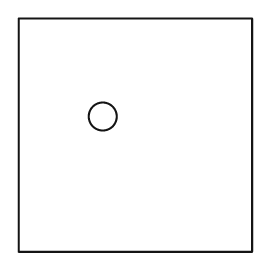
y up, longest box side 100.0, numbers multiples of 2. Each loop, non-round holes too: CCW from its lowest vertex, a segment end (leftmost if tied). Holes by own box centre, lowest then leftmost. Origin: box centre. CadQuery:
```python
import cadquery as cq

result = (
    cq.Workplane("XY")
    .moveTo(-50.0, -50.0)
    .lineTo(50.0, -50.0)
    .lineTo(50.0, 50.0)
    .lineTo(-50.0, 50.0)
    .close()
    .moveTo(-14.0, 8.0)
    .circle(6.0)
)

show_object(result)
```